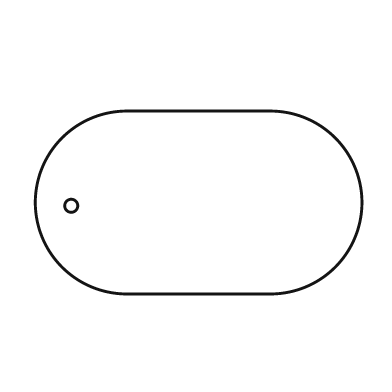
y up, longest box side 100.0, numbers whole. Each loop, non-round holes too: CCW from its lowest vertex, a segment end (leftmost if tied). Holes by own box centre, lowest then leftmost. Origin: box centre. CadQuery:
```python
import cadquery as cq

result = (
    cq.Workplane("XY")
    .moveTo(-22.0, -28.0)
    .lineTo(22.0, -28.0)
    .threePointArc((50.0, 0.0), (22.0, 28.0))
    .lineTo(-22.0, 28.0)
    .threePointArc((-50.0, 0.0), (-22.0, -28.0))
    .close()
    .moveTo(-39.0, -1.0)
    .circle(2.0)
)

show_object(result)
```